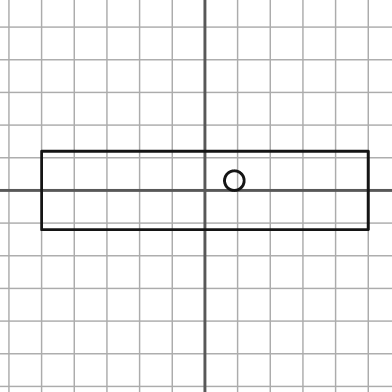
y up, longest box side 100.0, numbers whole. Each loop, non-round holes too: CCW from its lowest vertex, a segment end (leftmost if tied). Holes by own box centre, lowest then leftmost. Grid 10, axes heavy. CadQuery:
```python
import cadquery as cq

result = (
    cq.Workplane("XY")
    .moveTo(-50.0, -12.0)
    .lineTo(50.0, -12.0)
    .lineTo(50.0, 12.0)
    .lineTo(-50.0, 12.0)
    .close()
    .moveTo(9.0, 3.0)
    .circle(3.0)
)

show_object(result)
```